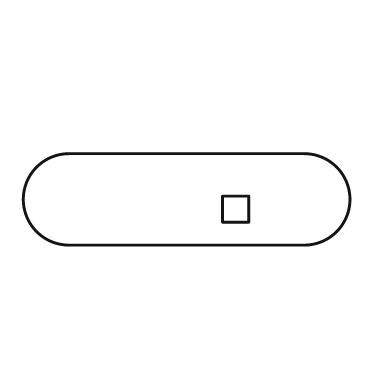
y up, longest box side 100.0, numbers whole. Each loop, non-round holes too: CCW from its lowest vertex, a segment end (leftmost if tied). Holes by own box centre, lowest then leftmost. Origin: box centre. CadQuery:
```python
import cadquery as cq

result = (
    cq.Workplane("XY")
    .moveTo(-36.0, -14.0)
    .lineTo(36.0, -14.0)
    .threePointArc((50.0, 0.0), (36.0, 14.0))
    .lineTo(-36.0, 14.0)
    .threePointArc((-50.0, 0.0), (-36.0, -14.0))
    .close()
    .moveTo(11.0, -7.0)
    .lineTo(19.0, -7.0)
    .lineTo(19.0, 1.0)
    .lineTo(11.0, 1.0)
    .close()
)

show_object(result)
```